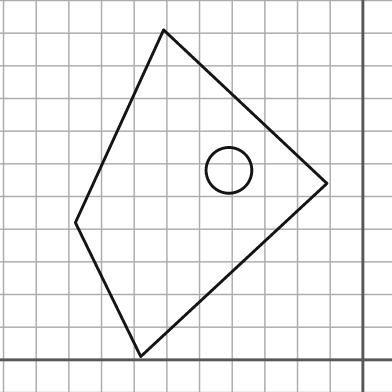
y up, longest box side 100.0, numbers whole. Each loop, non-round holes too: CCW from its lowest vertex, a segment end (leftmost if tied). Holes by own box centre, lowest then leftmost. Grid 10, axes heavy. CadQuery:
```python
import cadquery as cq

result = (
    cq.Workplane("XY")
    .moveTo(-68.0, 1.0)
    .lineTo(-11.0, 54.0)
    .lineTo(-61.0, 101.0)
    .lineTo(-88.0, 42.0)
    .close()
    .moveTo(-41.0, 58.0)
    .circle(7.0)
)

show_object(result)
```